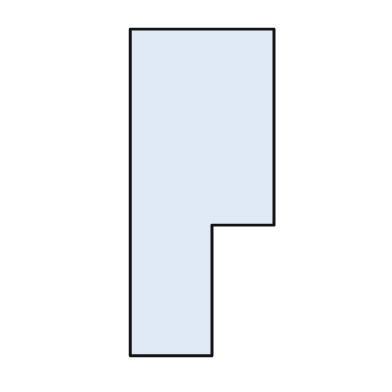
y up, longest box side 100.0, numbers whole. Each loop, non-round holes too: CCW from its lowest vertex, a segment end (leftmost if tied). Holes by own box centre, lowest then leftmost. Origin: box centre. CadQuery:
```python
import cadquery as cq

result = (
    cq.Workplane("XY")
    .moveTo(-22.0, -50.0)
    .lineTo(3.0, -50.0)
    .lineTo(3.0, -10.0)
    .lineTo(22.0, -10.0)
    .lineTo(22.0, 50.0)
    .lineTo(-22.0, 50.0)
    .close()
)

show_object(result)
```